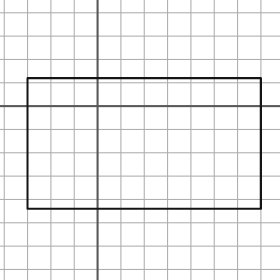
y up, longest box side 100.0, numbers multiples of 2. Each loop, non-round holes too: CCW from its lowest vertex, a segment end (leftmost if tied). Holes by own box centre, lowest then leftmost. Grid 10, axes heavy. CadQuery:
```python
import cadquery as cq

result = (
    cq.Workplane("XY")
    .moveTo(-30.0, -44.0)
    .lineTo(70.0, -44.0)
    .lineTo(70.0, 12.0)
    .lineTo(-30.0, 12.0)
    .close()
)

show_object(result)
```